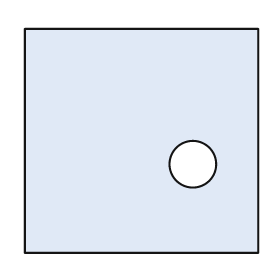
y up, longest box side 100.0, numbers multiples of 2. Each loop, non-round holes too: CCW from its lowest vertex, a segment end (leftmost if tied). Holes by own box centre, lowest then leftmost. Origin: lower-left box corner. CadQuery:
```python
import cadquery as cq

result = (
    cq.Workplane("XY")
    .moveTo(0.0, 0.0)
    .lineTo(100.0, 0.0)
    .lineTo(100.0, 96.0)
    .lineTo(0.0, 96.0)
    .close()
    .moveTo(72.0, 38.0)
    .circle(10.0)
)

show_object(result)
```